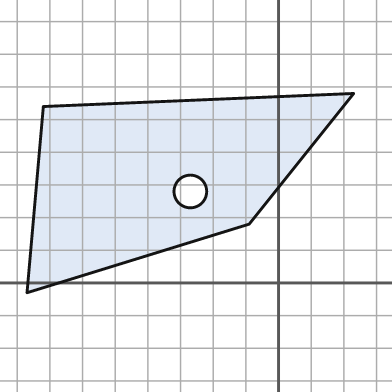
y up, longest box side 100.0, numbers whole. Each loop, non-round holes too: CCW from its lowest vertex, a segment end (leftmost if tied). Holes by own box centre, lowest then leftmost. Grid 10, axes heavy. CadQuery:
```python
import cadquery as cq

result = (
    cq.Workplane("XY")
    .moveTo(-77.0, -3.0)
    .lineTo(-9.0, 18.0)
    .lineTo(23.0, 58.0)
    .lineTo(-72.0, 54.0)
    .close()
    .moveTo(-27.0, 28.0)
    .circle(5.0)
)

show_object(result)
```